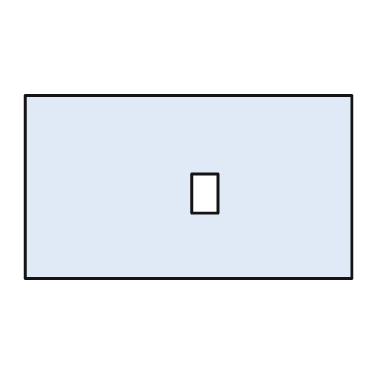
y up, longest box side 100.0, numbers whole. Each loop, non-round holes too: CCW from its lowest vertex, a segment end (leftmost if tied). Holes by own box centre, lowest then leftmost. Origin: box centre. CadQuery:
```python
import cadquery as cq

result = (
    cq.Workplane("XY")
    .moveTo(-50.0, -28.0)
    .lineTo(50.0, -28.0)
    .lineTo(50.0, 28.0)
    .lineTo(-50.0, 28.0)
    .close()
    .moveTo(1.0, -8.0)
    .lineTo(9.0, -8.0)
    .lineTo(9.0, 4.0)
    .lineTo(1.0, 4.0)
    .close()
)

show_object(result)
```